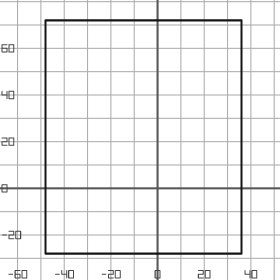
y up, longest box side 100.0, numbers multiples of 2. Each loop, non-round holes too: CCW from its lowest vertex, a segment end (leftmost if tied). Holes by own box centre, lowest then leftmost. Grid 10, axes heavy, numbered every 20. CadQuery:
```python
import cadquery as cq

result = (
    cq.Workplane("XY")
    .moveTo(-48.0, -28.0)
    .lineTo(36.0, -28.0)
    .lineTo(36.0, 72.0)
    .lineTo(-48.0, 72.0)
    .close()
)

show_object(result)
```